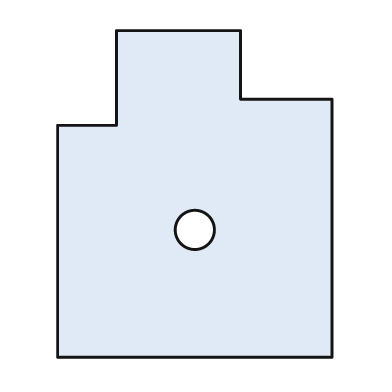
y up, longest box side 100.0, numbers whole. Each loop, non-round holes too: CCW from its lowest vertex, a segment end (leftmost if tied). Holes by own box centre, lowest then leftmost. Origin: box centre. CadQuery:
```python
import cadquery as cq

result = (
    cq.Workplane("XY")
    .moveTo(-42.0, -50.0)
    .lineTo(42.0, -50.0)
    .lineTo(42.0, 29.0)
    .lineTo(14.0, 29.0)
    .lineTo(14.0, 50.0)
    .lineTo(-24.0, 50.0)
    .lineTo(-24.0, 21.0)
    .lineTo(-42.0, 21.0)
    .close()
    .moveTo(0.0, -11.0)
    .circle(6.0)
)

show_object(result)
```